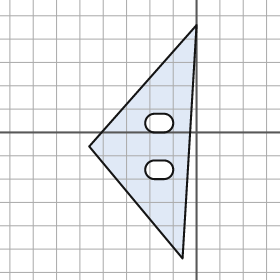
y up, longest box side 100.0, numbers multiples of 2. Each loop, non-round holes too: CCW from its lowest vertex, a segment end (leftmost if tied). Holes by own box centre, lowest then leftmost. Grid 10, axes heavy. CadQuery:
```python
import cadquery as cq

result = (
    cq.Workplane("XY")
    .moveTo(-6.0, -54.0)
    .lineTo(0.0, 46.0)
    .lineTo(-46.0, -6.0)
    .close()
    .moveTo(-18.0, -20.0)
    .lineTo(-14.0, -20.0)
    .threePointArc((-10.0, -16.0), (-14.0, -12.0))
    .lineTo(-18.0, -12.0)
    .threePointArc((-22.0, -16.0), (-18.0, -20.0))
    .close()
    .moveTo(-18.0, 0.0)
    .lineTo(-14.0, 0.0)
    .threePointArc((-10.0, 4.0), (-14.0, 8.0))
    .lineTo(-18.0, 8.0)
    .threePointArc((-22.0, 4.0), (-18.0, 0.0))
    .close()
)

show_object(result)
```